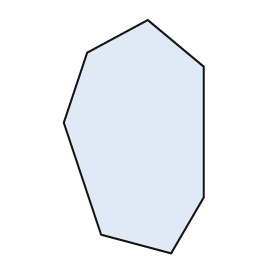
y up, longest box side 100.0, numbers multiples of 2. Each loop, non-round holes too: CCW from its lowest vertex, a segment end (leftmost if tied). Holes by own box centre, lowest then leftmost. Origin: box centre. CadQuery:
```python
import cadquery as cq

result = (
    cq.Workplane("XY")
    .moveTo(16.0, -50.0)
    .lineTo(30.0, -26.0)
    .lineTo(30.0, 30.0)
    .lineTo(6.0, 50.0)
    .lineTo(-20.0, 36.0)
    .lineTo(-30.0, 6.0)
    .lineTo(-14.0, -42.0)
    .close()
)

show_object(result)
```